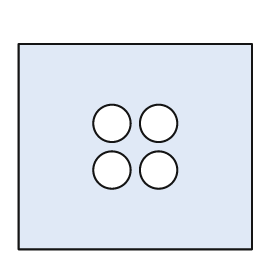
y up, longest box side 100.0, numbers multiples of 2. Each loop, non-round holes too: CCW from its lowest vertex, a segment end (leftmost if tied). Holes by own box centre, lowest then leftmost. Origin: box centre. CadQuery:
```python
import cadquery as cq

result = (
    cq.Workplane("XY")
    .moveTo(-50.0, -44.0)
    .lineTo(50.0, -44.0)
    .lineTo(50.0, 44.0)
    .lineTo(-50.0, 44.0)
    .close()
    .moveTo(-10.0, -10.0)
    .circle(8.0)
    .moveTo(10.0, -10.0)
    .circle(8.0)
    .moveTo(-10.0, 10.0)
    .circle(8.0)
    .moveTo(10.0, 10.0)
    .circle(8.0)
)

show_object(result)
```